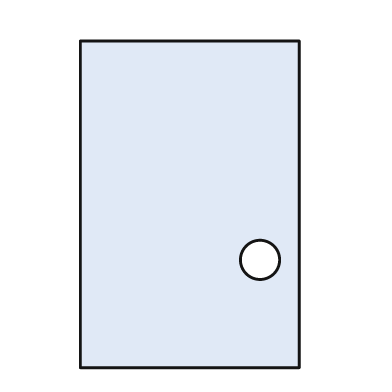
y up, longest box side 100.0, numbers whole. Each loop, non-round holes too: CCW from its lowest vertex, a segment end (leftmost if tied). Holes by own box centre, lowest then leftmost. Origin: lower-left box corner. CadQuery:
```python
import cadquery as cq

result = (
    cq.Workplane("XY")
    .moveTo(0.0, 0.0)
    .lineTo(67.0, 0.0)
    .lineTo(67.0, 100.0)
    .lineTo(0.0, 100.0)
    .close()
    .moveTo(55.0, 33.0)
    .circle(6.0)
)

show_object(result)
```